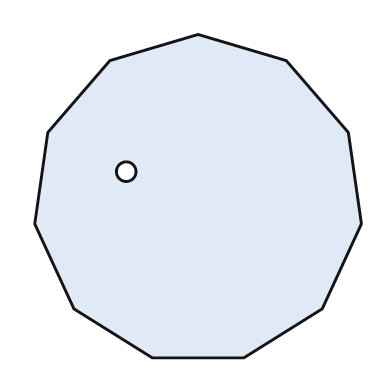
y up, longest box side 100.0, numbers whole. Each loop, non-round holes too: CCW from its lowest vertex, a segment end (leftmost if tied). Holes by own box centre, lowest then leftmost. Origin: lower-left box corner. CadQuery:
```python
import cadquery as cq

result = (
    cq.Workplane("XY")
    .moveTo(36.0, 0.0)
    .lineTo(64.0, 0.0)
    .lineTo(88.0, 15.0)
    .lineTo(100.0, 41.0)
    .lineTo(96.0, 69.0)
    .lineTo(77.0, 91.0)
    .lineTo(50.0, 99.0)
    .lineTo(23.0, 91.0)
    .lineTo(4.0, 69.0)
    .lineTo(0.0, 41.0)
    .lineTo(12.0, 15.0)
    .close()
    .moveTo(28.0, 57.0)
    .circle(3.0)
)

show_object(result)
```